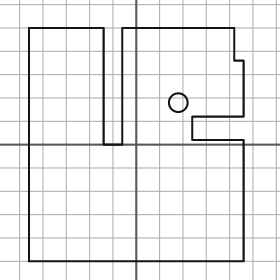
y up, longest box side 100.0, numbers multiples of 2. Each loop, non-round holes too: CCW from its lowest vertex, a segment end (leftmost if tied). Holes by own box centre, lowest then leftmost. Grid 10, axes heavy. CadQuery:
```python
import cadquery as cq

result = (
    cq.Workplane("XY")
    .moveTo(-46.0, -50.0)
    .lineTo(46.0, -50.0)
    .lineTo(46.0, 2.0)
    .lineTo(24.0, 2.0)
    .lineTo(24.0, 12.0)
    .lineTo(46.0, 12.0)
    .lineTo(46.0, 36.0)
    .lineTo(42.0, 36.0)
    .lineTo(42.0, 50.0)
    .lineTo(-6.0, 50.0)
    .lineTo(-6.0, 0.0)
    .lineTo(-14.0, 0.0)
    .lineTo(-14.0, 50.0)
    .lineTo(-46.0, 50.0)
    .close()
    .moveTo(18.0, 18.0)
    .circle(4.0)
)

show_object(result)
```